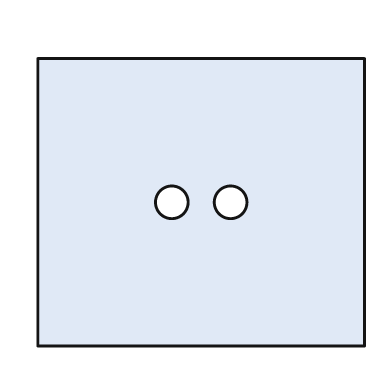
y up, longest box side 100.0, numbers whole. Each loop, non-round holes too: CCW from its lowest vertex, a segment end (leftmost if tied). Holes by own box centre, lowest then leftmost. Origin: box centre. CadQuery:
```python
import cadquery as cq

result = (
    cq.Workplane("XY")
    .moveTo(-50.0, -44.0)
    .lineTo(50.0, -44.0)
    .lineTo(50.0, 44.0)
    .lineTo(-50.0, 44.0)
    .close()
    .moveTo(-9.0, 0.0)
    .circle(5.0)
    .moveTo(9.0, 0.0)
    .circle(5.0)
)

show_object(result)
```